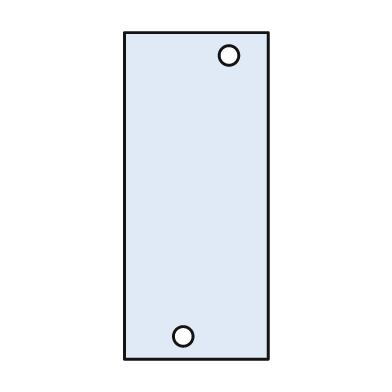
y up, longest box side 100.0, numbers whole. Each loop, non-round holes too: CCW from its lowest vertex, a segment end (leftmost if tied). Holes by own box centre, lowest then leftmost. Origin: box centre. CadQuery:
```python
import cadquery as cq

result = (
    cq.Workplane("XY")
    .moveTo(-22.0, -50.0)
    .lineTo(22.0, -50.0)
    .lineTo(22.0, 50.0)
    .lineTo(-22.0, 50.0)
    .close()
    .moveTo(-4.0, -43.0)
    .circle(3.0)
    .moveTo(10.0, 43.0)
    .circle(3.0)
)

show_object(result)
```